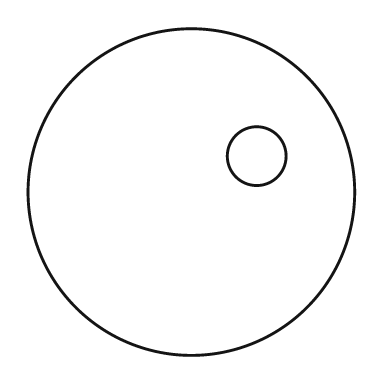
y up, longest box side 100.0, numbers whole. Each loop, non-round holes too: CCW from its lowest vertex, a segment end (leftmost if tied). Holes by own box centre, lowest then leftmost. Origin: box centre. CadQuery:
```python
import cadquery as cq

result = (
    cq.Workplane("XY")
    .moveTo(0.0, 0.0)
    .circle(50.0)
    .moveTo(20.0, 11.0)
    .circle(9.0)
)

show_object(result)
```